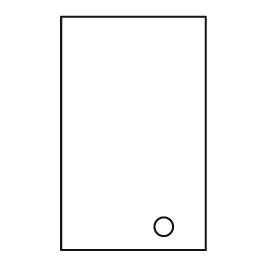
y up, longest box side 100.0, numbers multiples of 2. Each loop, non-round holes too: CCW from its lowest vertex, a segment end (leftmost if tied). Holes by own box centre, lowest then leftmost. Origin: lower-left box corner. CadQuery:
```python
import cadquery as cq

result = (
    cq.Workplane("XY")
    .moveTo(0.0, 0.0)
    .lineTo(62.0, 0.0)
    .lineTo(62.0, 100.0)
    .lineTo(0.0, 100.0)
    .close()
    .moveTo(44.0, 10.0)
    .circle(4.0)
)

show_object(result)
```